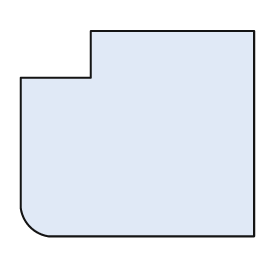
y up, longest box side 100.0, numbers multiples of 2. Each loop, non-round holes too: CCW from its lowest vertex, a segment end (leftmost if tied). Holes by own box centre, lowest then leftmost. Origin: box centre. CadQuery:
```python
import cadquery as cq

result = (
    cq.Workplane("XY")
    .moveTo(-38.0, -44.0)
    .lineTo(50.0, -44.0)
    .lineTo(50.0, 44.0)
    .lineTo(-20.0, 44.0)
    .lineTo(-20.0, 24.0)
    .lineTo(-50.0, 24.0)
    .lineTo(-50.0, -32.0)
    .threePointArc((-46.0, -40.0), (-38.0, -44.0))
    .close()
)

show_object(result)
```